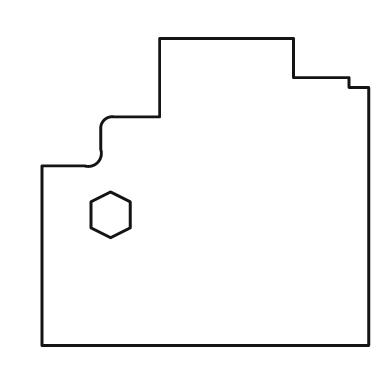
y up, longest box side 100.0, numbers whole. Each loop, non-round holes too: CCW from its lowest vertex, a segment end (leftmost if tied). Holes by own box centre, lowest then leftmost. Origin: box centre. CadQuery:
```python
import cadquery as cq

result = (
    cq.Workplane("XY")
    .moveTo(-50.0, -47.0)
    .lineTo(50.0, -47.0)
    .lineTo(50.0, 32.0)
    .lineTo(44.0, 32.0)
    .lineTo(44.0, 35.0)
    .lineTo(27.0, 35.0)
    .lineTo(27.0, 47.0)
    .lineTo(-14.0, 47.0)
    .lineTo(-14.0, 23.0)
    .lineTo(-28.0, 23.0)
    .threePointArc((-31.0, 22.0), (-32.0, 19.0))
    .lineTo(-32.0, 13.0)
    .threePointArc((-33.0, 9.0), (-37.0, 8.0))
    .lineTo(-50.0, 8.0)
    .close()
    .moveTo(-29.0, -14.0)
    .lineTo(-23.0, -11.0)
    .lineTo(-23.0, -3.0)
    .lineTo(-29.0, 0.0)
    .lineTo(-35.0, -3.0)
    .lineTo(-35.0, -11.0)
    .close()
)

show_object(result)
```